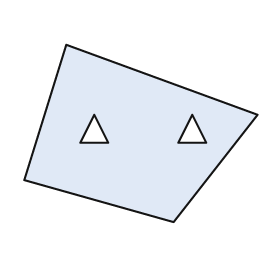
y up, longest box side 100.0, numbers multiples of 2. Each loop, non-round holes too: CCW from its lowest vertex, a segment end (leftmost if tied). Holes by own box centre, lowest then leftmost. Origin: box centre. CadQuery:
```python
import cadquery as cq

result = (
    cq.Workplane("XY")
    .moveTo(14.0, -38.0)
    .lineTo(50.0, 8.0)
    .lineTo(-32.0, 38.0)
    .lineTo(-50.0, -20.0)
    .close()
    .moveTo(-26.0, -4.0)
    .lineTo(-14.0, -4.0)
    .lineTo(-20.0, 8.0)
    .close()
    .moveTo(16.0, -4.0)
    .lineTo(28.0, -4.0)
    .lineTo(22.0, 8.0)
    .close()
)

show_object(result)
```